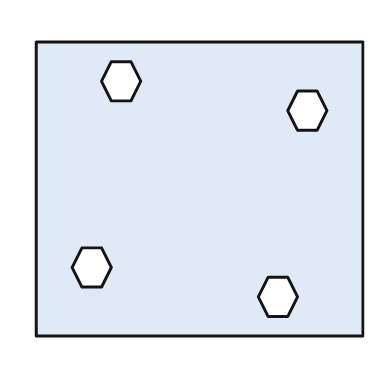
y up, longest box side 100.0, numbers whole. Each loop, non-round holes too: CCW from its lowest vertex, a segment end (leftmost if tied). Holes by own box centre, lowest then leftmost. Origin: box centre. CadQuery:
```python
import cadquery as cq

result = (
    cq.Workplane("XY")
    .moveTo(-50.0, -45.0)
    .lineTo(50.0, -45.0)
    .lineTo(50.0, 45.0)
    .lineTo(-50.0, 45.0)
    .close()
    .moveTo(21.0, -39.0)
    .lineTo(27.0, -39.0)
    .lineTo(30.0, -33.0)
    .lineTo(27.0, -27.0)
    .lineTo(21.0, -27.0)
    .lineTo(18.0, -33.0)
    .close()
    .moveTo(-36.0, -30.0)
    .lineTo(-30.0, -30.0)
    .lineTo(-27.0, -24.0)
    .lineTo(-30.0, -18.0)
    .lineTo(-36.0, -18.0)
    .lineTo(-39.0, -24.0)
    .close()
    .moveTo(30.0, 18.0)
    .lineTo(36.0, 18.0)
    .lineTo(39.0, 24.0)
    .lineTo(36.0, 30.0)
    .lineTo(30.0, 30.0)
    .lineTo(27.0, 24.0)
    .close()
    .moveTo(-27.0, 27.0)
    .lineTo(-21.0, 27.0)
    .lineTo(-18.0, 33.0)
    .lineTo(-21.0, 39.0)
    .lineTo(-27.0, 39.0)
    .lineTo(-30.0, 33.0)
    .close()
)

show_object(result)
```